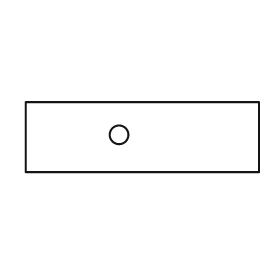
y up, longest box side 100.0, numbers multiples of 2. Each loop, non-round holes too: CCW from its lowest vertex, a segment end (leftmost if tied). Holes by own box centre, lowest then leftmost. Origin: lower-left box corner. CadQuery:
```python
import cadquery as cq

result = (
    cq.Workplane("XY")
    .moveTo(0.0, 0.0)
    .lineTo(100.0, 0.0)
    .lineTo(100.0, 30.0)
    .lineTo(0.0, 30.0)
    .close()
    .moveTo(40.0, 16.0)
    .circle(4.0)
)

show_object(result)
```